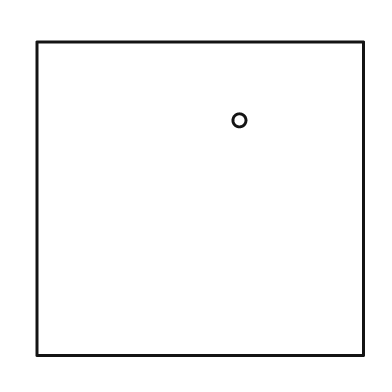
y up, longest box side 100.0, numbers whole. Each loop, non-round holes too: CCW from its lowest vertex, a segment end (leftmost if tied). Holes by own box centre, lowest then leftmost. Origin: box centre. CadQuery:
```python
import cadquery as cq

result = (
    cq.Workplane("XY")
    .moveTo(-50.0, -48.0)
    .lineTo(50.0, -48.0)
    .lineTo(50.0, 48.0)
    .lineTo(-50.0, 48.0)
    .close()
    .moveTo(12.0, 24.0)
    .circle(2.0)
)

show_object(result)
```